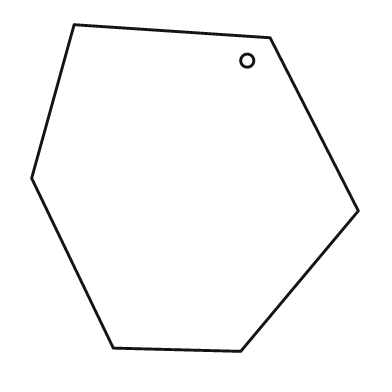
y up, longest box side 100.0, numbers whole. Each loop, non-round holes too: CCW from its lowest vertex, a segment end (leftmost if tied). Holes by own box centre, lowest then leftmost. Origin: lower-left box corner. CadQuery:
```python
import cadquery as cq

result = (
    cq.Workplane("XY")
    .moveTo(64.0, 0.0)
    .lineTo(100.0, 43.0)
    .lineTo(73.0, 96.0)
    .lineTo(13.0, 100.0)
    .lineTo(0.0, 53.0)
    .lineTo(25.0, 1.0)
    .close()
    .moveTo(66.0, 89.0)
    .circle(2.0)
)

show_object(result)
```